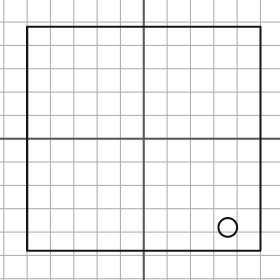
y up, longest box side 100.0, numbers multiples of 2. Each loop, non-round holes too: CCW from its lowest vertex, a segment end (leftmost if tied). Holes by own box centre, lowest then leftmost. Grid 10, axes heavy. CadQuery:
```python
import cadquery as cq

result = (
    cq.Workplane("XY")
    .moveTo(-50.0, -48.0)
    .lineTo(50.0, -48.0)
    .lineTo(50.0, 48.0)
    .lineTo(-50.0, 48.0)
    .close()
    .moveTo(36.0, -38.0)
    .circle(4.0)
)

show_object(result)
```